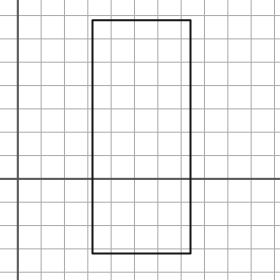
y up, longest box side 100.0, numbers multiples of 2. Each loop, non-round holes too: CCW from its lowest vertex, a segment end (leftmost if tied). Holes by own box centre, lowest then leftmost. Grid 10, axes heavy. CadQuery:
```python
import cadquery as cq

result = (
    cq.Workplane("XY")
    .moveTo(32.0, -32.0)
    .lineTo(74.0, -32.0)
    .lineTo(74.0, 68.0)
    .lineTo(32.0, 68.0)
    .close()
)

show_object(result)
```